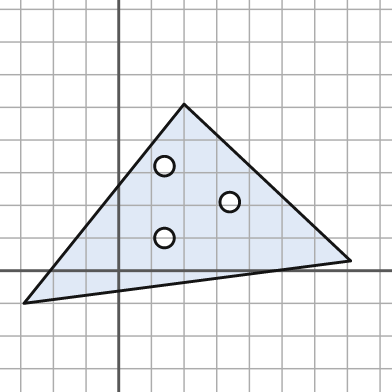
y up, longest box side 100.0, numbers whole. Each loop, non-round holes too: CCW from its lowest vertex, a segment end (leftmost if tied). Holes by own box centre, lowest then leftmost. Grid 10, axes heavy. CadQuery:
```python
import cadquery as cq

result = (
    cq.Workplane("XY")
    .moveTo(-29.0, -10.0)
    .lineTo(71.0, 3.0)
    .lineTo(20.0, 51.0)
    .close()
    .moveTo(14.0, 10.0)
    .circle(3.0)
    .moveTo(34.0, 21.0)
    .circle(3.0)
    .moveTo(14.0, 32.0)
    .circle(3.0)
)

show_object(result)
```